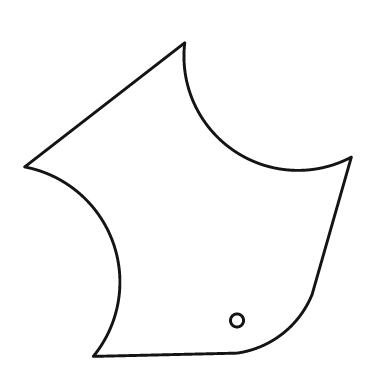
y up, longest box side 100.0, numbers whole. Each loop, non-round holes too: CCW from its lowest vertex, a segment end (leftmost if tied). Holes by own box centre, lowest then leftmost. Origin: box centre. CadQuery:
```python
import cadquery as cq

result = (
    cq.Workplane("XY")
    .moveTo(-29.0, -48.0)
    .lineTo(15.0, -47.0)
    .threePointArc((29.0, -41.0), (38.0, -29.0))
    .lineTo(50.0, 13.0)
    .threePointArc((14.0, 15.0), (-1.0, 48.0))
    .lineTo(-50.0, 10.0)
    .threePointArc((-23.0, -13.0), (-29.0, -48.0))
    .close()
    .moveTo(15.0, -37.0)
    .circle(2.0)
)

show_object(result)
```